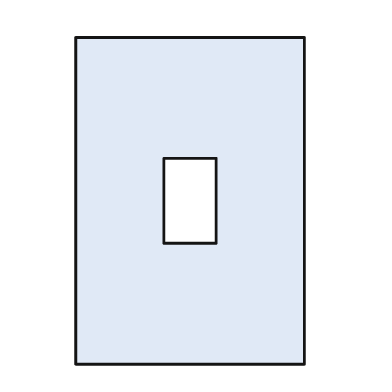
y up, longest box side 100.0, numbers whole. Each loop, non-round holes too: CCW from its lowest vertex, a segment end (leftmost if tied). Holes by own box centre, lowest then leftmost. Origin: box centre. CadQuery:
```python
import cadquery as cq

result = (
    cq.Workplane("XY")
    .moveTo(-35.0, -50.0)
    .lineTo(35.0, -50.0)
    .lineTo(35.0, 50.0)
    .lineTo(-35.0, 50.0)
    .close()
    .moveTo(-8.0, -13.0)
    .lineTo(8.0, -13.0)
    .lineTo(8.0, 13.0)
    .lineTo(-8.0, 13.0)
    .close()
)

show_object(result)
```